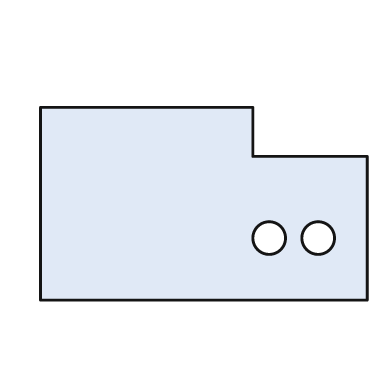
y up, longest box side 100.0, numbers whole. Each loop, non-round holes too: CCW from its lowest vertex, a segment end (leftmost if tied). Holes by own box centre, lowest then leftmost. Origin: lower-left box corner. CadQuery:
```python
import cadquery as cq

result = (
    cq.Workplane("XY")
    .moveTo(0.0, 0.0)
    .lineTo(100.0, 0.0)
    .lineTo(100.0, 44.0)
    .lineTo(65.0, 44.0)
    .lineTo(65.0, 59.0)
    .lineTo(0.0, 59.0)
    .close()
    .moveTo(70.0, 19.0)
    .circle(5.0)
    .moveTo(85.0, 19.0)
    .circle(5.0)
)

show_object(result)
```